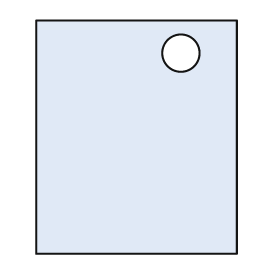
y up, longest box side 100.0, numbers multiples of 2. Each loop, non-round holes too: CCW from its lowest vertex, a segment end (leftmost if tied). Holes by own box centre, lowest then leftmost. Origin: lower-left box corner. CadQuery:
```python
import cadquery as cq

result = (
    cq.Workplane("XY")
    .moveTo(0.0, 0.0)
    .lineTo(86.0, 0.0)
    .lineTo(86.0, 100.0)
    .lineTo(0.0, 100.0)
    .close()
    .moveTo(62.0, 86.0)
    .circle(8.0)
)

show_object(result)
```